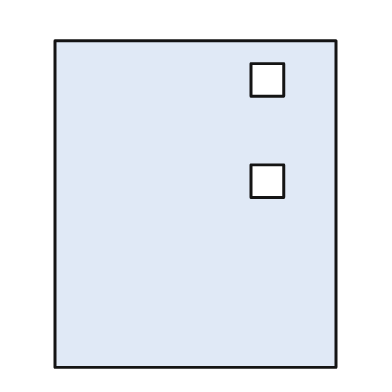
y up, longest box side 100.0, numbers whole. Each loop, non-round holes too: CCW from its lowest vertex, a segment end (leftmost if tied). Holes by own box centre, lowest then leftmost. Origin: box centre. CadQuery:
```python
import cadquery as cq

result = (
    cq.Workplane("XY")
    .moveTo(-43.0, -50.0)
    .lineTo(43.0, -50.0)
    .lineTo(43.0, 50.0)
    .lineTo(-43.0, 50.0)
    .close()
    .moveTo(17.0, 2.0)
    .lineTo(27.0, 2.0)
    .lineTo(27.0, 12.0)
    .lineTo(17.0, 12.0)
    .close()
    .moveTo(17.0, 33.0)
    .lineTo(27.0, 33.0)
    .lineTo(27.0, 43.0)
    .lineTo(17.0, 43.0)
    .close()
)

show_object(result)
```